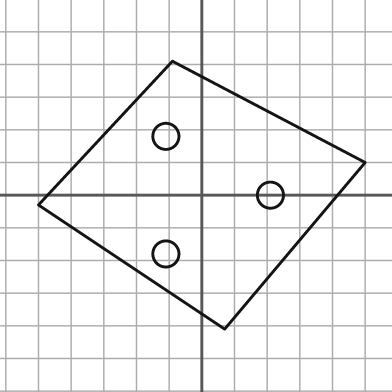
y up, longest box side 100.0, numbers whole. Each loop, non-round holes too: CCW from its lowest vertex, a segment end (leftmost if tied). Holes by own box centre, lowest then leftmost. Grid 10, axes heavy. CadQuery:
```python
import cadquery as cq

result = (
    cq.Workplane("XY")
    .moveTo(7.0, -41.0)
    .lineTo(50.0, 10.0)
    .lineTo(-9.0, 41.0)
    .lineTo(-50.0, -3.0)
    .close()
    .moveTo(-11.0, -18.0)
    .circle(4.0)
    .moveTo(21.0, 0.0)
    .circle(4.0)
    .moveTo(-11.0, 18.0)
    .circle(4.0)
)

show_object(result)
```